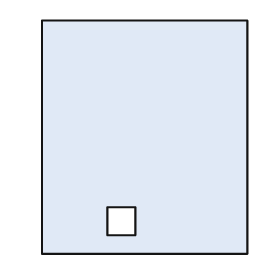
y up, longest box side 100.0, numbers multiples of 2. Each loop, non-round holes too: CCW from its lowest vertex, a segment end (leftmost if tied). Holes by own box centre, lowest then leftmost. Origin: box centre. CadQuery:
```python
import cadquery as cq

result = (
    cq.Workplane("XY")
    .moveTo(-44.0, -50.0)
    .lineTo(44.0, -50.0)
    .lineTo(44.0, 50.0)
    .lineTo(-44.0, 50.0)
    .close()
    .moveTo(-16.0, -42.0)
    .lineTo(-4.0, -42.0)
    .lineTo(-4.0, -30.0)
    .lineTo(-16.0, -30.0)
    .close()
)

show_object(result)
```